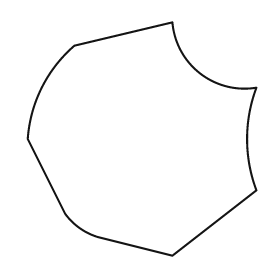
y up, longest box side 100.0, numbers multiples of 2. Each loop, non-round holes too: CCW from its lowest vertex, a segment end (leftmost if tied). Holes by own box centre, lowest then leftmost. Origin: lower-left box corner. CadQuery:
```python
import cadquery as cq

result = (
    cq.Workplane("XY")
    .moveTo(62.0, 0.0)
    .lineTo(98.0, 28.0)
    .threePointArc((94.0, 50.0), (98.0, 72.0))
    .threePointArc((74.0, 78.0), (62.0, 100.0))
    .lineTo(20.0, 90.0)
    .threePointArc((6.0, 72.0), (0.0, 50.0))
    .lineTo(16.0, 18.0)
    .threePointArc((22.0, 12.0), (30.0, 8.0))
    .close()
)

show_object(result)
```